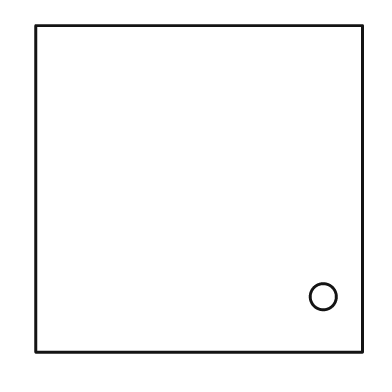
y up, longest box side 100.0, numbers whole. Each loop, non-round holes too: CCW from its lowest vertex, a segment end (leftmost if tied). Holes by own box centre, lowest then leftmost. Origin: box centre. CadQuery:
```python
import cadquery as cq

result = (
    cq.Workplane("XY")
    .moveTo(-50.0, -50.0)
    .lineTo(50.0, -50.0)
    .lineTo(50.0, 50.0)
    .lineTo(-50.0, 50.0)
    .close()
    .moveTo(38.0, -33.0)
    .circle(4.0)
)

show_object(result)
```